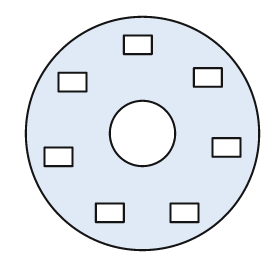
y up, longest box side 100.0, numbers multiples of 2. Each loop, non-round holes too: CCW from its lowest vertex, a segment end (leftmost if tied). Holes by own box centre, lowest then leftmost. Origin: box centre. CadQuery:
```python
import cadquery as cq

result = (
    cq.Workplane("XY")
    .moveTo(0.0, 0.0)
    .circle(50.0)
    .moveTo(-20.0, -38.0)
    .lineTo(-8.0, -38.0)
    .lineTo(-8.0, -30.0)
    .lineTo(-20.0, -30.0)
    .close()
    .moveTo(12.0, -38.0)
    .lineTo(24.0, -38.0)
    .lineTo(24.0, -30.0)
    .lineTo(12.0, -30.0)
    .close()
    .moveTo(-42.0, -14.0)
    .lineTo(-30.0, -14.0)
    .lineTo(-30.0, -6.0)
    .lineTo(-42.0, -6.0)
    .close()
    .moveTo(30.0, -10.0)
    .lineTo(42.0, -10.0)
    .lineTo(42.0, -2.0)
    .lineTo(30.0, -2.0)
    .close()
    .moveTo(0.0, 0.0)
    .circle(14.0)
    .moveTo(-36.0, 18.0)
    .lineTo(-24.0, 18.0)
    .lineTo(-24.0, 26.0)
    .lineTo(-36.0, 26.0)
    .close()
    .moveTo(22.0, 20.0)
    .lineTo(34.0, 20.0)
    .lineTo(34.0, 28.0)
    .lineTo(22.0, 28.0)
    .close()
    .moveTo(-8.0, 34.0)
    .lineTo(4.0, 34.0)
    .lineTo(4.0, 42.0)
    .lineTo(-8.0, 42.0)
    .close()
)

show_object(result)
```